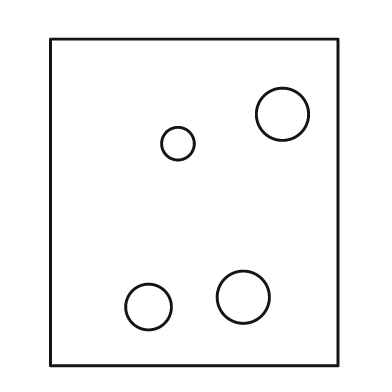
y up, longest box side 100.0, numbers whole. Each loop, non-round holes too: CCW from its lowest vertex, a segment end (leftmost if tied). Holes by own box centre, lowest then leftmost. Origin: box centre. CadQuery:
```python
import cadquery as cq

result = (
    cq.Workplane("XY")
    .moveTo(-44.0, -50.0)
    .lineTo(44.0, -50.0)
    .lineTo(44.0, 50.0)
    .lineTo(-44.0, 50.0)
    .close()
    .moveTo(-14.0, -32.0)
    .circle(7.0)
    .moveTo(15.0, -29.0)
    .circle(8.0)
    .moveTo(-5.0, 18.0)
    .circle(5.0)
    .moveTo(27.0, 27.0)
    .circle(8.0)
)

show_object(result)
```